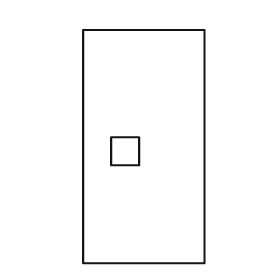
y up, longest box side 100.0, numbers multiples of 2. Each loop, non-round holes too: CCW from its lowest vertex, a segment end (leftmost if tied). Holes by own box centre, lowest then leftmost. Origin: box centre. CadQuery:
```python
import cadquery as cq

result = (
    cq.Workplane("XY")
    .moveTo(-26.0, -50.0)
    .lineTo(26.0, -50.0)
    .lineTo(26.0, 50.0)
    .lineTo(-26.0, 50.0)
    .close()
    .moveTo(-14.0, -8.0)
    .lineTo(-2.0, -8.0)
    .lineTo(-2.0, 4.0)
    .lineTo(-14.0, 4.0)
    .close()
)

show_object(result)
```